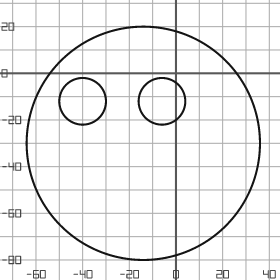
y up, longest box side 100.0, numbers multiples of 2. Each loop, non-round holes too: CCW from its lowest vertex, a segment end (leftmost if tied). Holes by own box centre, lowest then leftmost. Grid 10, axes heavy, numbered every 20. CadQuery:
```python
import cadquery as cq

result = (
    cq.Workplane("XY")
    .moveTo(-14.0, -30.0)
    .circle(50.0)
    .moveTo(-40.0, -12.0)
    .circle(10.0)
    .moveTo(-6.0, -12.0)
    .circle(10.0)
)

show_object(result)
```